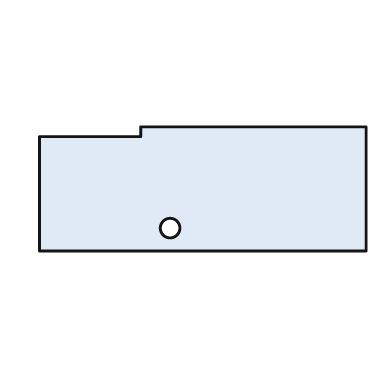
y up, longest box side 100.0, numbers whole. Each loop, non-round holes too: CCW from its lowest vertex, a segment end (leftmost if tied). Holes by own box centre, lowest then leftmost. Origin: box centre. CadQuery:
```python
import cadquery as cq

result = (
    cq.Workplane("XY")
    .moveTo(-50.0, -19.0)
    .lineTo(50.0, -19.0)
    .lineTo(50.0, 19.0)
    .lineTo(-19.0, 19.0)
    .lineTo(-19.0, 16.0)
    .lineTo(-50.0, 16.0)
    .close()
    .moveTo(-10.0, -12.0)
    .circle(3.0)
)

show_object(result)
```